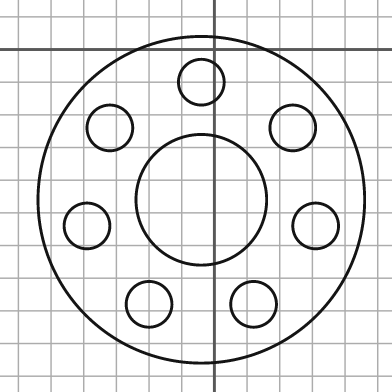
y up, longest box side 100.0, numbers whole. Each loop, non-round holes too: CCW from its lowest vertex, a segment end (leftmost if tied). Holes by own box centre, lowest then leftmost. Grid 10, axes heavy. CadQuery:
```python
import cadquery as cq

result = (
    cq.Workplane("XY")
    .moveTo(-4.0, -46.0)
    .circle(50.0)
    .moveTo(-20.0, -78.0)
    .circle(7.0)
    .moveTo(12.0, -78.0)
    .circle(7.0)
    .moveTo(-39.0, -54.0)
    .circle(7.0)
    .moveTo(31.0, -54.0)
    .circle(7.0)
    .moveTo(-4.0, -46.0)
    .circle(20.0)
    .moveTo(-32.0, -24.0)
    .circle(7.0)
    .moveTo(24.0, -24.0)
    .circle(7.0)
    .moveTo(-4.0, -10.0)
    .circle(7.0)
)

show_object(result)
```